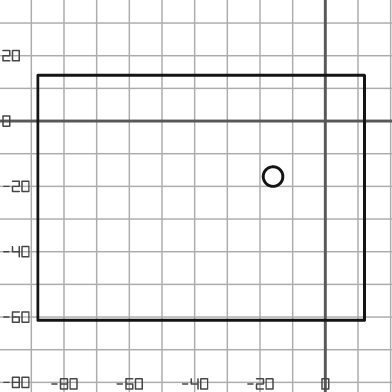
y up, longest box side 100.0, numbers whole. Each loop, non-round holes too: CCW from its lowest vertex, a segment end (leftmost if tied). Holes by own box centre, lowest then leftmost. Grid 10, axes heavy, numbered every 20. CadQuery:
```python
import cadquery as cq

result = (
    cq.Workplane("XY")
    .moveTo(-88.0, -61.0)
    .lineTo(12.0, -61.0)
    .lineTo(12.0, 14.0)
    .lineTo(-88.0, 14.0)
    .close()
    .moveTo(-16.0, -17.0)
    .circle(3.0)
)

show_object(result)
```